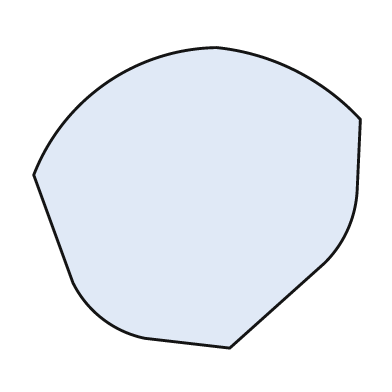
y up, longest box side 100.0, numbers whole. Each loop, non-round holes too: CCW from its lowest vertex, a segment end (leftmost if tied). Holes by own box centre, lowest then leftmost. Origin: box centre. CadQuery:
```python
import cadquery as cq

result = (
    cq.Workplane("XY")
    .moveTo(10.0, -46.0)
    .lineTo(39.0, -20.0)
    .threePointArc((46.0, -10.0), (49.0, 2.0))
    .lineTo(50.0, 24.0)
    .threePointArc((30.0, 39.0), (6.0, 46.0))
    .threePointArc((-28.0, 35.0), (-50.0, 7.0))
    .lineTo(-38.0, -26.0)
    .threePointArc((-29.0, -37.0), (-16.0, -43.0))
    .close()
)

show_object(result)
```